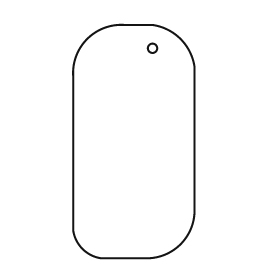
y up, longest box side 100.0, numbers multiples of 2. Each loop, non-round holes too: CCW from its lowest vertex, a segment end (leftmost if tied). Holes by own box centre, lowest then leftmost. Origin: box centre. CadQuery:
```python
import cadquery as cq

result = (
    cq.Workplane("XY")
    .moveTo(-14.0, -50.0)
    .lineTo(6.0, -50.0)
    .threePointArc((20.0, -44.0), (26.0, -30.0))
    .lineTo(26.0, 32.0)
    .threePointArc((20.0, 44.0), (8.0, 50.0))
    .lineTo(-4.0, 50.0)
    .threePointArc((-20.0, 44.0), (-26.0, 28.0))
    .lineTo(-26.0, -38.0)
    .threePointArc((-22.0, -46.0), (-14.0, -50.0))
    .close()
    .moveTo(8.0, 40.0)
    .circle(2.0)
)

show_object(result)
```